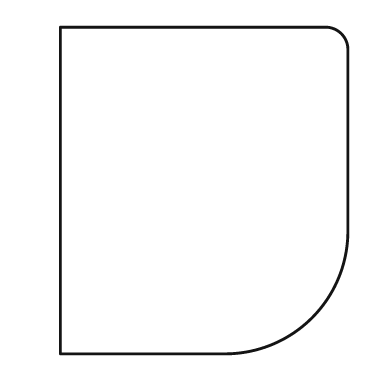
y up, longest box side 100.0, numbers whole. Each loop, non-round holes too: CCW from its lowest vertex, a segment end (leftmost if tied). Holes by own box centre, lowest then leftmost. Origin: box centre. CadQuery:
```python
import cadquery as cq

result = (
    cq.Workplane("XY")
    .moveTo(-44.0, -50.0)
    .lineTo(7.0, -50.0)
    .threePointArc((33.0, -39.0), (44.0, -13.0))
    .lineTo(44.0, 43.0)
    .threePointArc((42.0, 48.0), (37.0, 50.0))
    .lineTo(-44.0, 50.0)
    .close()
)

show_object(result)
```